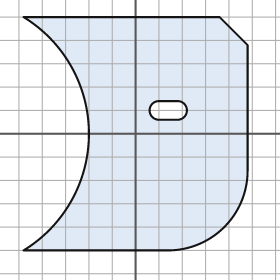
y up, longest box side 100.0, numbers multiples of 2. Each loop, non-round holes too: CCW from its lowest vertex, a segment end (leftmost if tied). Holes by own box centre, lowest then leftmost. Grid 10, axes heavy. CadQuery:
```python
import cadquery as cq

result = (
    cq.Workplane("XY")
    .moveTo(-48.0, -50.0)
    .lineTo(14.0, -50.0)
    .threePointArc((38.0, -40.0), (48.0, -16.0))
    .lineTo(48.0, 38.0)
    .lineTo(36.0, 50.0)
    .lineTo(-48.0, 50.0)
    .threePointArc((-20.0, 0.0), (-48.0, -50.0))
    .close()
    .moveTo(10.0, 6.0)
    .lineTo(18.0, 6.0)
    .threePointArc((22.0, 10.0), (18.0, 14.0))
    .lineTo(10.0, 14.0)
    .threePointArc((6.0, 10.0), (10.0, 6.0))
    .close()
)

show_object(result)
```